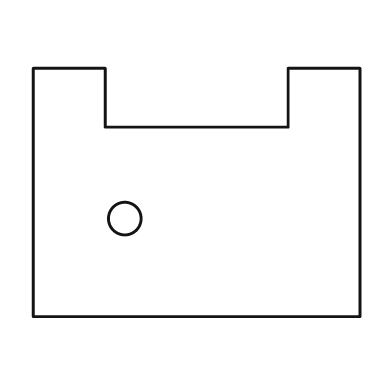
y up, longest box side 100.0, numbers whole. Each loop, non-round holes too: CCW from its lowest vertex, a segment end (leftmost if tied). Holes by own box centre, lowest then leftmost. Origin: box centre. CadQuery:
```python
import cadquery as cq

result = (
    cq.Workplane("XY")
    .moveTo(-50.0, -38.0)
    .lineTo(50.0, -38.0)
    .lineTo(50.0, 38.0)
    .lineTo(28.0, 38.0)
    .lineTo(28.0, 20.0)
    .lineTo(-28.0, 20.0)
    .lineTo(-28.0, 38.0)
    .lineTo(-50.0, 38.0)
    .close()
    .moveTo(-22.0, -8.0)
    .circle(5.0)
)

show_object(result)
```